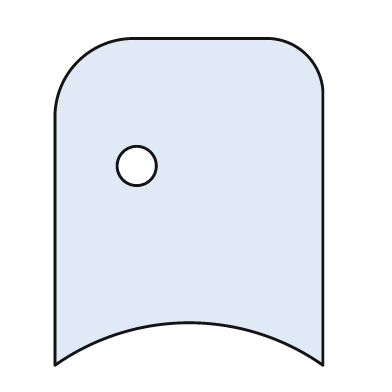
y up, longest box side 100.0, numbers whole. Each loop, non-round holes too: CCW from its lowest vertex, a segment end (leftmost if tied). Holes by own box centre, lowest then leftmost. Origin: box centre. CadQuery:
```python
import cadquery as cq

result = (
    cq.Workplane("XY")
    .moveTo(-41.0, -50.0)
    .threePointArc((0.0, -37.0), (41.0, -50.0))
    .lineTo(41.0, 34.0)
    .threePointArc((36.0, 45.0), (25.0, 50.0))
    .lineTo(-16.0, 50.0)
    .threePointArc((-34.0, 43.0), (-41.0, 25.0))
    .close()
    .moveTo(-16.0, 11.0)
    .circle(6.0)
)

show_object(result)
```